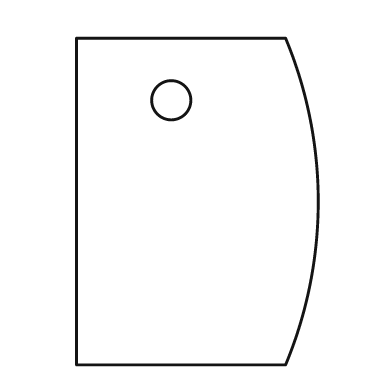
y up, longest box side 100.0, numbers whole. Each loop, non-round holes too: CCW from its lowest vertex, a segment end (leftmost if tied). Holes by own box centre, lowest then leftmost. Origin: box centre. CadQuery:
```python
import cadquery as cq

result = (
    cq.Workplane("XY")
    .moveTo(-37.0, -50.0)
    .lineTo(27.0, -50.0)
    .threePointArc((37.0, 0.0), (27.0, 50.0))
    .lineTo(-37.0, 50.0)
    .close()
    .moveTo(-8.0, 31.0)
    .circle(6.0)
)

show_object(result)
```